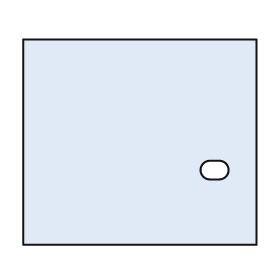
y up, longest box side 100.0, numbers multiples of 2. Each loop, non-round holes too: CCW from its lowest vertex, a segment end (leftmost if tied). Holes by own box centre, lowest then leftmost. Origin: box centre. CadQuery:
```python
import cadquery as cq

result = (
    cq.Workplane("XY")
    .moveTo(-50.0, -44.0)
    .lineTo(50.0, -44.0)
    .lineTo(50.0, 44.0)
    .lineTo(-50.0, 44.0)
    .close()
    .moveTo(30.0, -16.0)
    .lineTo(34.0, -16.0)
    .threePointArc((38.0, -12.0), (34.0, -8.0))
    .lineTo(30.0, -8.0)
    .threePointArc((26.0, -12.0), (30.0, -16.0))
    .close()
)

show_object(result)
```